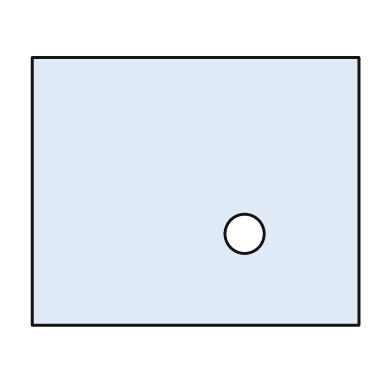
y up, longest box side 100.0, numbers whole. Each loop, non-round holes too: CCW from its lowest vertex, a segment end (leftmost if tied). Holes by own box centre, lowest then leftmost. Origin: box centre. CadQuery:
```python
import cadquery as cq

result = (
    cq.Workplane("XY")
    .moveTo(-50.0, -41.0)
    .lineTo(50.0, -41.0)
    .lineTo(50.0, 41.0)
    .lineTo(-50.0, 41.0)
    .close()
    .moveTo(15.0, -13.0)
    .circle(6.0)
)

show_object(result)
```